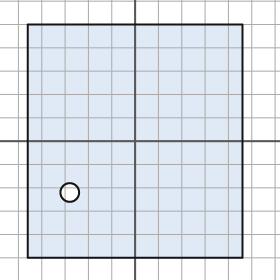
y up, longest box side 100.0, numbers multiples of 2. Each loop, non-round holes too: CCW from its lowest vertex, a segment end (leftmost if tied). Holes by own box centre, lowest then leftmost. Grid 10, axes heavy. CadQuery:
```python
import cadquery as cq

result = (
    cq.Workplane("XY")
    .moveTo(-46.0, -50.0)
    .lineTo(46.0, -50.0)
    .lineTo(46.0, 50.0)
    .lineTo(-46.0, 50.0)
    .close()
    .moveTo(-28.0, -22.0)
    .circle(4.0)
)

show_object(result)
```